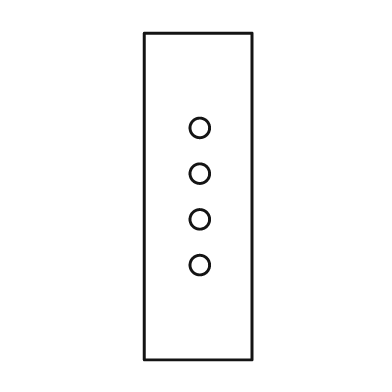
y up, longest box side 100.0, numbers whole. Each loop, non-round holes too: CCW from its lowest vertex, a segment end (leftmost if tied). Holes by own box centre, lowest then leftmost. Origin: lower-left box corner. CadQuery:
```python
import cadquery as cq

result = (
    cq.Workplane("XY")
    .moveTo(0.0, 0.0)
    .lineTo(33.0, 0.0)
    .lineTo(33.0, 100.0)
    .lineTo(0.0, 100.0)
    .close()
    .moveTo(17.0, 29.0)
    .circle(3.0)
    .moveTo(17.0, 43.0)
    .circle(3.0)
    .moveTo(17.0, 57.0)
    .circle(3.0)
    .moveTo(17.0, 71.0)
    .circle(3.0)
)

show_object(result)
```